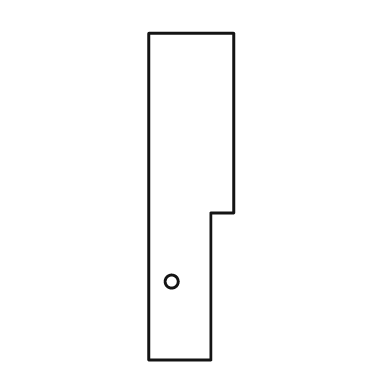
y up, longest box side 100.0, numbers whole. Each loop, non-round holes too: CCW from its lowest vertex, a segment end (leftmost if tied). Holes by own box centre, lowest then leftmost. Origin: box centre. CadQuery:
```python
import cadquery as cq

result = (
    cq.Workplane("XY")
    .moveTo(-13.0, -50.0)
    .lineTo(6.0, -50.0)
    .lineTo(6.0, -5.0)
    .lineTo(13.0, -5.0)
    .lineTo(13.0, 50.0)
    .lineTo(-13.0, 50.0)
    .close()
    .moveTo(-6.0, -26.0)
    .circle(2.0)
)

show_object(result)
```